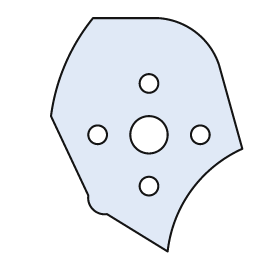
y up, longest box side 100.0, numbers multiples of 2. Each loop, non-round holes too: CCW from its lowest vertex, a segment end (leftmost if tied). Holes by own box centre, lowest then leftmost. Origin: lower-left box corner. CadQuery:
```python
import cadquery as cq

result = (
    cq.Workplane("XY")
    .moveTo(50.0, 0.0)
    .threePointArc((60.0, 26.0), (82.0, 44.0))
    .lineTo(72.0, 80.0)
    .threePointArc((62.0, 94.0), (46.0, 100.0))
    .lineTo(18.0, 100.0)
    .threePointArc((6.0, 80.0), (0.0, 58.0))
    .lineTo(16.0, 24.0)
    .threePointArc((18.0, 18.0), (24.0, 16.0))
    .close()
    .moveTo(42.0, 28.0)
    .circle(4.0)
    .moveTo(20.0, 50.0)
    .circle(4.0)
    .moveTo(42.0, 50.0)
    .circle(8.0)
    .moveTo(64.0, 50.0)
    .circle(4.0)
    .moveTo(42.0, 72.0)
    .circle(4.0)
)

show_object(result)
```